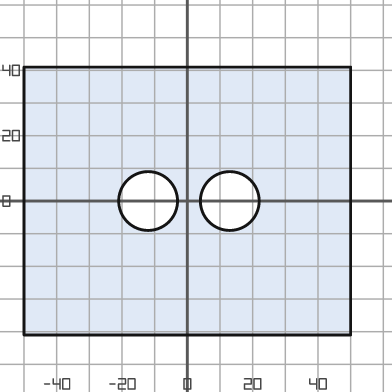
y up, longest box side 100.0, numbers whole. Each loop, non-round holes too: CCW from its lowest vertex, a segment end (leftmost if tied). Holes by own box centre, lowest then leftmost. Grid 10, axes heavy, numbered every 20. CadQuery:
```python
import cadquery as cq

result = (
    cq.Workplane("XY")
    .moveTo(-50.0, -41.0)
    .lineTo(50.0, -41.0)
    .lineTo(50.0, 41.0)
    .lineTo(-50.0, 41.0)
    .close()
    .moveTo(-12.0, 0.0)
    .circle(9.0)
    .moveTo(13.0, 0.0)
    .circle(9.0)
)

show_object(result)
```